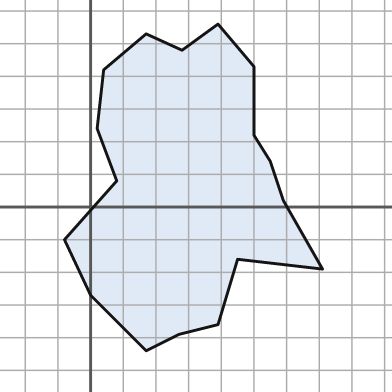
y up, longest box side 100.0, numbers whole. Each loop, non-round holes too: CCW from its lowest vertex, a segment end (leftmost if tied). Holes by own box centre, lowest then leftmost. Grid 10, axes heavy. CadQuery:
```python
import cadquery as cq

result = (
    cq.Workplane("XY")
    .moveTo(17.0, -44.0)
    .lineTo(27.0, -39.0)
    .lineTo(39.0, -36.0)
    .lineTo(45.0, -16.0)
    .lineTo(71.0, -19.0)
    .lineTo(59.0, 2.0)
    .lineTo(55.0, 14.0)
    .lineTo(50.0, 22.0)
    .lineTo(50.0, 43.0)
    .lineTo(39.0, 56.0)
    .lineTo(28.0, 48.0)
    .lineTo(17.0, 53.0)
    .lineTo(4.0, 42.0)
    .lineTo(2.0, 24.0)
    .lineTo(8.0, 8.0)
    .lineTo(-8.0, -10.0)
    .lineTo(0.0, -27.0)
    .close()
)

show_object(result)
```